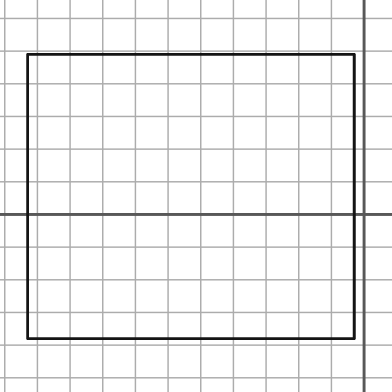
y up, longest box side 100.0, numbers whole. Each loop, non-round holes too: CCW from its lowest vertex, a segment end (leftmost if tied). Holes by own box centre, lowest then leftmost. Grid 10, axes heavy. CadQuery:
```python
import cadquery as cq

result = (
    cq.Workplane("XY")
    .moveTo(-103.0, -38.0)
    .lineTo(-3.0, -38.0)
    .lineTo(-3.0, 49.0)
    .lineTo(-103.0, 49.0)
    .close()
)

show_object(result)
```